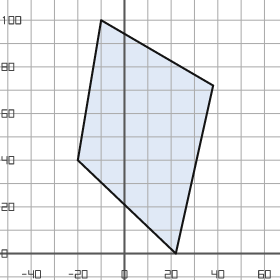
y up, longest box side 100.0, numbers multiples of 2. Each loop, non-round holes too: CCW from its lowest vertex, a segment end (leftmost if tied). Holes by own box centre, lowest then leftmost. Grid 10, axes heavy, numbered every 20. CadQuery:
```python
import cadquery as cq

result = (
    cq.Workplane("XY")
    .moveTo(22.0, 0.0)
    .lineTo(38.0, 72.0)
    .lineTo(-10.0, 100.0)
    .lineTo(-20.0, 40.0)
    .close()
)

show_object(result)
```